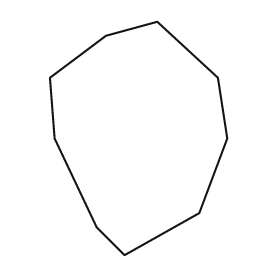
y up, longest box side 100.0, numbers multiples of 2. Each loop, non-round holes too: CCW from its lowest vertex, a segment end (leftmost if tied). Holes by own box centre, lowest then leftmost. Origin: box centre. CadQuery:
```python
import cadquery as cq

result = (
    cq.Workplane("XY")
    .moveTo(-6.0, -50.0)
    .lineTo(26.0, -32.0)
    .lineTo(38.0, 0.0)
    .lineTo(34.0, 26.0)
    .lineTo(8.0, 50.0)
    .lineTo(-14.0, 44.0)
    .lineTo(-38.0, 26.0)
    .lineTo(-36.0, 0.0)
    .lineTo(-18.0, -38.0)
    .close()
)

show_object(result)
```